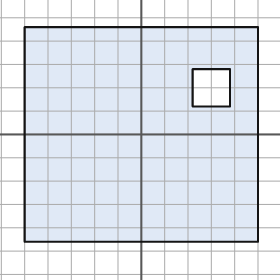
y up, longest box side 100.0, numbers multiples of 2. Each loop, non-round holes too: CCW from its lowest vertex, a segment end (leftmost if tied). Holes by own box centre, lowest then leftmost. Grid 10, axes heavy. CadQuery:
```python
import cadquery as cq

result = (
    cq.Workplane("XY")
    .moveTo(-50.0, -46.0)
    .lineTo(50.0, -46.0)
    .lineTo(50.0, 46.0)
    .lineTo(-50.0, 46.0)
    .close()
    .moveTo(22.0, 12.0)
    .lineTo(38.0, 12.0)
    .lineTo(38.0, 28.0)
    .lineTo(22.0, 28.0)
    .close()
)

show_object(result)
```